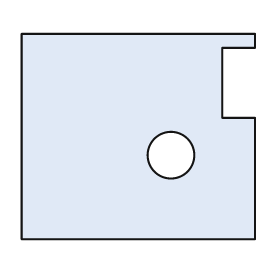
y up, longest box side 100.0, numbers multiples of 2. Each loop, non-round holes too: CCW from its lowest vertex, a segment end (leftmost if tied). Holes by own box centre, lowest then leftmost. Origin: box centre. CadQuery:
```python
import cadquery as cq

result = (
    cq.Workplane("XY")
    .moveTo(-50.0, -44.0)
    .lineTo(50.0, -44.0)
    .lineTo(50.0, 8.0)
    .lineTo(36.0, 8.0)
    .lineTo(36.0, 38.0)
    .lineTo(50.0, 38.0)
    .lineTo(50.0, 44.0)
    .lineTo(-50.0, 44.0)
    .close()
    .moveTo(14.0, -8.0)
    .circle(10.0)
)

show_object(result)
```